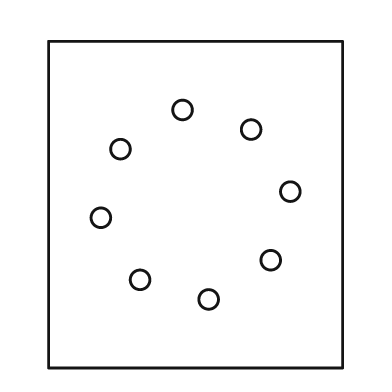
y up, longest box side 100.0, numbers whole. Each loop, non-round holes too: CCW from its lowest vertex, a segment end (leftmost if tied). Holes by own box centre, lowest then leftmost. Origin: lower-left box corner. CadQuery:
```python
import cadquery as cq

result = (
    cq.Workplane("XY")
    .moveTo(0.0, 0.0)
    .lineTo(90.0, 0.0)
    .lineTo(90.0, 100.0)
    .lineTo(0.0, 100.0)
    .close()
    .moveTo(49.0, 21.0)
    .circle(3.0)
    .moveTo(28.0, 27.0)
    .circle(3.0)
    .moveTo(68.0, 33.0)
    .circle(3.0)
    .moveTo(16.0, 46.0)
    .circle(3.0)
    .moveTo(74.0, 54.0)
    .circle(3.0)
    .moveTo(22.0, 67.0)
    .circle(3.0)
    .moveTo(62.0, 73.0)
    .circle(3.0)
    .moveTo(41.0, 79.0)
    .circle(3.0)
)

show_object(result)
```